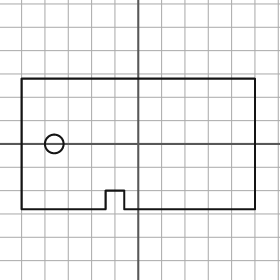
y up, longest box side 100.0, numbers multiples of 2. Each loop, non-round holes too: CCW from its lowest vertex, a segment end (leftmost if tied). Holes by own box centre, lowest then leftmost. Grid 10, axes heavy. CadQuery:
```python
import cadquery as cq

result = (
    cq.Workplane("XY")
    .moveTo(-50.0, -28.0)
    .lineTo(-14.0, -28.0)
    .lineTo(-14.0, -20.0)
    .lineTo(-6.0, -20.0)
    .lineTo(-6.0, -28.0)
    .lineTo(50.0, -28.0)
    .lineTo(50.0, 28.0)
    .lineTo(-50.0, 28.0)
    .close()
    .moveTo(-36.0, 0.0)
    .circle(4.0)
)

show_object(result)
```